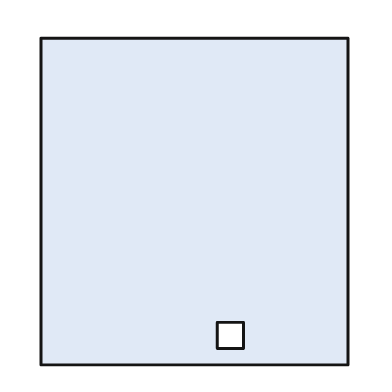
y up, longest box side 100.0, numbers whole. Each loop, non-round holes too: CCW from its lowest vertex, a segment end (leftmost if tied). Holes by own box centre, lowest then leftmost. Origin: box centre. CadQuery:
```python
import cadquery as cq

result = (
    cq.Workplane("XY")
    .moveTo(-47.0, -50.0)
    .lineTo(47.0, -50.0)
    .lineTo(47.0, 50.0)
    .lineTo(-47.0, 50.0)
    .close()
    .moveTo(7.0, -45.0)
    .lineTo(15.0, -45.0)
    .lineTo(15.0, -37.0)
    .lineTo(7.0, -37.0)
    .close()
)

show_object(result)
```